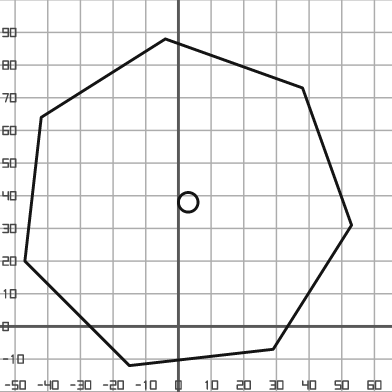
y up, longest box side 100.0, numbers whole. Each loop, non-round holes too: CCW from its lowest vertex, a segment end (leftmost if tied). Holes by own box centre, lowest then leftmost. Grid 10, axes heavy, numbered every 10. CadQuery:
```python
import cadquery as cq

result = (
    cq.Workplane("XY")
    .moveTo(-15.0, -12.0)
    .lineTo(29.0, -7.0)
    .lineTo(53.0, 31.0)
    .lineTo(38.0, 73.0)
    .lineTo(-4.0, 88.0)
    .lineTo(-42.0, 64.0)
    .lineTo(-47.0, 20.0)
    .close()
    .moveTo(3.0, 38.0)
    .circle(3.0)
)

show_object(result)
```